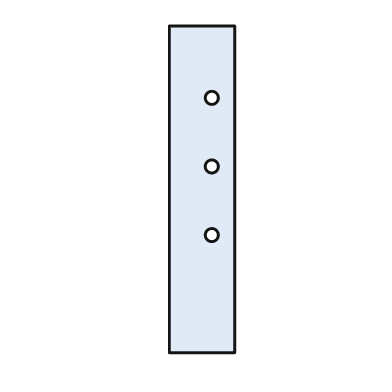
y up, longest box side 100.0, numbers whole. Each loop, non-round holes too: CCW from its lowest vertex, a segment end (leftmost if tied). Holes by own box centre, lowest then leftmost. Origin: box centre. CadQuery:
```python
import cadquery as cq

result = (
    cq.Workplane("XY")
    .moveTo(-10.0, -50.0)
    .lineTo(10.0, -50.0)
    .lineTo(10.0, 50.0)
    .lineTo(-10.0, 50.0)
    .close()
    .moveTo(3.0, -14.0)
    .circle(2.0)
    .moveTo(3.0, 7.0)
    .circle(2.0)
    .moveTo(3.0, 28.0)
    .circle(2.0)
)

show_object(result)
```